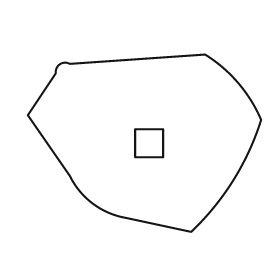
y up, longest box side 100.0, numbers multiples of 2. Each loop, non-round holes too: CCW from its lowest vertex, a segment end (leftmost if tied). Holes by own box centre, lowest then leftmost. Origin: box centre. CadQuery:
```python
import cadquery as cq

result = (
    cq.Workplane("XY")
    .moveTo(20.0, -38.0)
    .threePointArc((38.0, -16.0), (50.0, 10.0))
    .threePointArc((40.0, 26.0), (26.0, 38.0))
    .lineTo(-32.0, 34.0)
    .threePointArc((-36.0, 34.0), (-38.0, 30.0))
    .lineTo(-50.0, 12.0)
    .lineTo(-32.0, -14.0)
    .threePointArc((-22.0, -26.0), (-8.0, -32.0))
    .close()
    .moveTo(-4.0, -6.0)
    .lineTo(8.0, -6.0)
    .lineTo(8.0, 6.0)
    .lineTo(-4.0, 6.0)
    .close()
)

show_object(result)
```